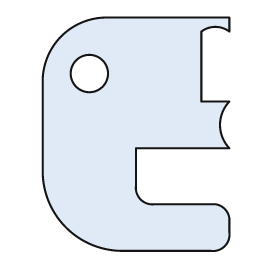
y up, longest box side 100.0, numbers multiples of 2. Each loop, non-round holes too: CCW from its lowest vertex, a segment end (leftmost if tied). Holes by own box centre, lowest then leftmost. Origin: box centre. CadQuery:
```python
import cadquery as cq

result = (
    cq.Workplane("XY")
    .moveTo(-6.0, -50.0)
    .lineTo(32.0, -50.0)
    .threePointArc((38.0, -48.0), (40.0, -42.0))
    .lineTo(40.0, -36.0)
    .threePointArc((38.0, -32.0), (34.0, -30.0))
    .lineTo(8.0, -30.0)
    .threePointArc((2.0, -28.0), (0.0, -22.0))
    .lineTo(0.0, -6.0)
    .lineTo(40.0, -6.0)
    .threePointArc((36.0, 4.0), (40.0, 14.0))
    .lineTo(28.0, 14.0)
    .lineTo(28.0, 44.0)
    .threePointArc((34.0, 46.0), (40.0, 44.0))
    .lineTo(40.0, 50.0)
    .lineTo(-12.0, 50.0)
    .threePointArc((-32.0, 42.0), (-40.0, 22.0))
    .lineTo(-40.0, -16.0)
    .threePointArc((-30.0, -40.0), (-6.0, -50.0))
    .close()
    .moveTo(-20.0, 26.0)
    .circle(8.0)
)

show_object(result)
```